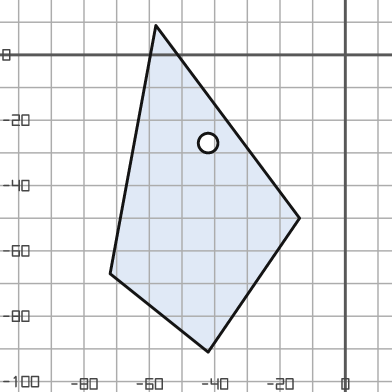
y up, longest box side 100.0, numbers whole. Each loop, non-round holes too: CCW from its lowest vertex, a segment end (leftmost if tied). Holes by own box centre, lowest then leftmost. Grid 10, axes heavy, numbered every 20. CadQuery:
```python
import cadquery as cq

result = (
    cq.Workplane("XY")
    .moveTo(-42.0, -91.0)
    .lineTo(-14.0, -50.0)
    .lineTo(-58.0, 9.0)
    .lineTo(-72.0, -67.0)
    .close()
    .moveTo(-42.0, -27.0)
    .circle(3.0)
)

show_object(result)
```